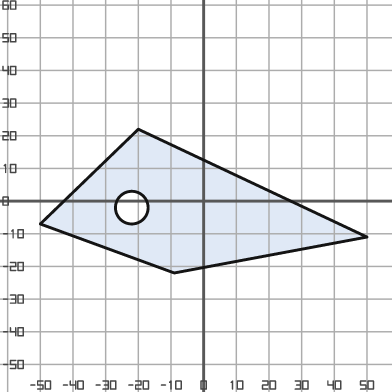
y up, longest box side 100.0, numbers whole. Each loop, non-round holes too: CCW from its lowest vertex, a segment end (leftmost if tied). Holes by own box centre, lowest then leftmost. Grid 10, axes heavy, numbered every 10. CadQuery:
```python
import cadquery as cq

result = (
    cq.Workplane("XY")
    .moveTo(-9.0, -22.0)
    .lineTo(50.0, -11.0)
    .lineTo(-20.0, 22.0)
    .lineTo(-50.0, -7.0)
    .close()
    .moveTo(-22.0, -2.0)
    .circle(5.0)
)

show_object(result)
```